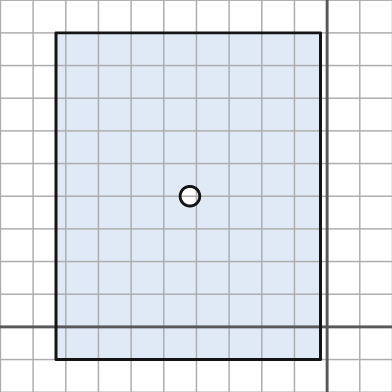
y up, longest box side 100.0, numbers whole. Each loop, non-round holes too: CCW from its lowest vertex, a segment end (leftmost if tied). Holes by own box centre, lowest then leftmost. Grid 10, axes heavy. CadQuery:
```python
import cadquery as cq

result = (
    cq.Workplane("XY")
    .moveTo(-83.0, -10.0)
    .lineTo(-2.0, -10.0)
    .lineTo(-2.0, 90.0)
    .lineTo(-83.0, 90.0)
    .close()
    .moveTo(-42.0, 40.0)
    .circle(3.0)
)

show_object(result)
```